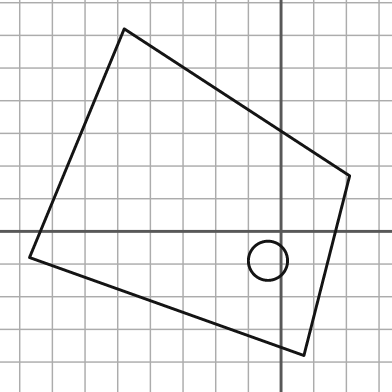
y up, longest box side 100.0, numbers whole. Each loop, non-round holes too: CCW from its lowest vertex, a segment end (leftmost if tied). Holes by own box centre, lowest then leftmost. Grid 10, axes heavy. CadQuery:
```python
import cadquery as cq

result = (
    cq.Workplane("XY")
    .moveTo(7.0, -38.0)
    .lineTo(21.0, 17.0)
    .lineTo(-48.0, 62.0)
    .lineTo(-77.0, -8.0)
    .close()
    .moveTo(-4.0, -9.0)
    .circle(6.0)
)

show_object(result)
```